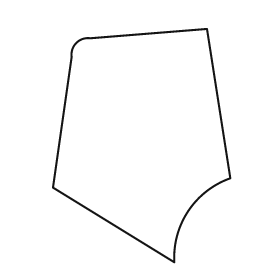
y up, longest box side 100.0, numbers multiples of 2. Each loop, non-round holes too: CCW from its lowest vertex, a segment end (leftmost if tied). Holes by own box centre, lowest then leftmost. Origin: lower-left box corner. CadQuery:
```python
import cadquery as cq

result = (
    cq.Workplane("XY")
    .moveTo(52.0, 0.0)
    .threePointArc((58.0, 22.0), (76.0, 36.0))
    .lineTo(66.0, 100.0)
    .lineTo(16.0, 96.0)
    .threePointArc((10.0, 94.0), (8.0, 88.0))
    .lineTo(0.0, 32.0)
    .close()
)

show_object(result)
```